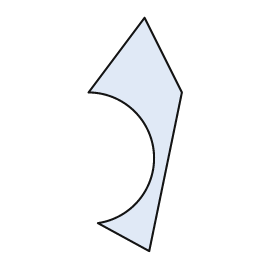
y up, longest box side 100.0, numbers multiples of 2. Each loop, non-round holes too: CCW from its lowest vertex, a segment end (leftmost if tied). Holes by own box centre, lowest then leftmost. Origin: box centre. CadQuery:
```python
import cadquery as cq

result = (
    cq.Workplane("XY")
    .moveTo(6.0, -50.0)
    .lineTo(20.0, 18.0)
    .lineTo(4.0, 50.0)
    .lineTo(-20.0, 18.0)
    .threePointArc((8.0, -8.0), (-16.0, -38.0))
    .close()
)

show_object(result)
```